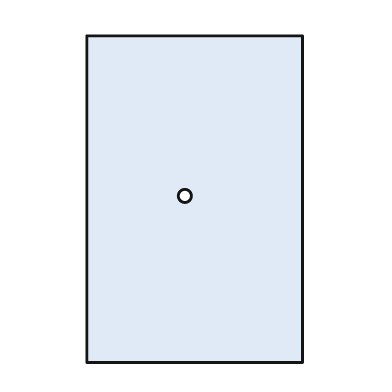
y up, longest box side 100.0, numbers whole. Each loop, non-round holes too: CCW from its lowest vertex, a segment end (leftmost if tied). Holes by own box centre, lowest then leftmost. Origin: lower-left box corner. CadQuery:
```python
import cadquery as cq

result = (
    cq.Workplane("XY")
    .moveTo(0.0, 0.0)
    .lineTo(66.0, 0.0)
    .lineTo(66.0, 100.0)
    .lineTo(0.0, 100.0)
    .close()
    .moveTo(30.0, 51.0)
    .circle(2.0)
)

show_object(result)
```